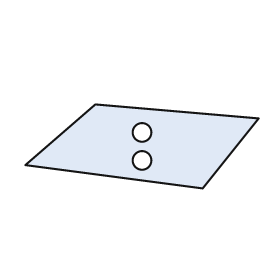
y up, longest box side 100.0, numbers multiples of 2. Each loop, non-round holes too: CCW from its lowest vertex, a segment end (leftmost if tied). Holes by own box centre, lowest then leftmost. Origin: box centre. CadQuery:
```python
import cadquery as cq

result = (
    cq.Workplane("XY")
    .moveTo(26.0, -18.0)
    .lineTo(50.0, 12.0)
    .lineTo(-20.0, 18.0)
    .lineTo(-50.0, -8.0)
    .close()
    .moveTo(0.0, -6.0)
    .circle(4.0)
    .moveTo(0.0, 6.0)
    .circle(4.0)
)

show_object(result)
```